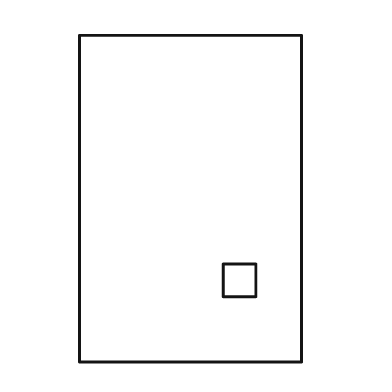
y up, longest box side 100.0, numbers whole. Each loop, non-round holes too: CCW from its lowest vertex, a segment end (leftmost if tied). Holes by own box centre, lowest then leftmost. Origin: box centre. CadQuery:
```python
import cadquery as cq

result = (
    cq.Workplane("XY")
    .moveTo(-34.0, -50.0)
    .lineTo(34.0, -50.0)
    .lineTo(34.0, 50.0)
    .lineTo(-34.0, 50.0)
    .close()
    .moveTo(10.0, -30.0)
    .lineTo(20.0, -30.0)
    .lineTo(20.0, -20.0)
    .lineTo(10.0, -20.0)
    .close()
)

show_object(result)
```